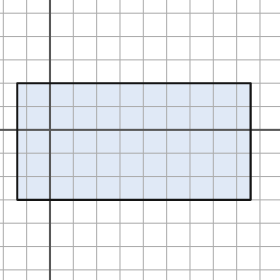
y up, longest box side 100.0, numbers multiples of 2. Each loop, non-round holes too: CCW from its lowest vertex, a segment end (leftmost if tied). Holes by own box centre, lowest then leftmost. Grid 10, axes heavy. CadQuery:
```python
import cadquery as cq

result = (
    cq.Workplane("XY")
    .moveTo(-14.0, -30.0)
    .lineTo(86.0, -30.0)
    .lineTo(86.0, 20.0)
    .lineTo(-14.0, 20.0)
    .close()
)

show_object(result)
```